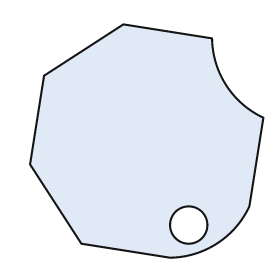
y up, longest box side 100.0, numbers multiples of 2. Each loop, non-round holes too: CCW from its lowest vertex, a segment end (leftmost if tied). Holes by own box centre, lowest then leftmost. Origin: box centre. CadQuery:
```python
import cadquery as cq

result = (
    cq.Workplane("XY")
    .moveTo(10.0, -50.0)
    .threePointArc((30.0, -44.0), (44.0, -28.0))
    .lineTo(50.0, 10.0)
    .threePointArc((34.0, 24.0), (28.0, 44.0))
    .lineTo(-10.0, 50.0)
    .lineTo(-44.0, 28.0)
    .lineTo(-50.0, -10.0)
    .lineTo(-28.0, -44.0)
    .close()
    .moveTo(18.0, -36.0)
    .circle(8.0)
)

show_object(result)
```